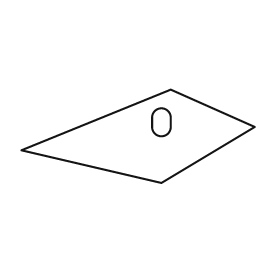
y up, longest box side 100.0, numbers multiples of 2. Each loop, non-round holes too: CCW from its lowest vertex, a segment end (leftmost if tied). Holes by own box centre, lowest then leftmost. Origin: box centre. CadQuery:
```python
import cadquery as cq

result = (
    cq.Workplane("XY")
    .moveTo(10.0, -20.0)
    .lineTo(50.0, 4.0)
    .lineTo(14.0, 20.0)
    .lineTo(-50.0, -6.0)
    .close()
    .moveTo(6.0, 4.0)
    .threePointArc((10.0, 0.0), (14.0, 4.0))
    .lineTo(14.0, 8.0)
    .threePointArc((10.0, 12.0), (6.0, 8.0))
    .close()
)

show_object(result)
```